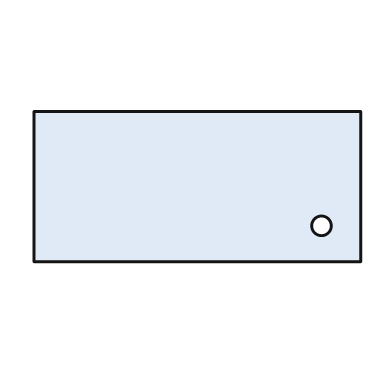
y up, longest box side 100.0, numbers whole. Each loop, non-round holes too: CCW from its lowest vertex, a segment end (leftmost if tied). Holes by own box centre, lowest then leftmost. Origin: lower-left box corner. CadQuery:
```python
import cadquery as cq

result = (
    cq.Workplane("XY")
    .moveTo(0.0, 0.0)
    .lineTo(100.0, 0.0)
    .lineTo(100.0, 46.0)
    .lineTo(0.0, 46.0)
    .close()
    .moveTo(88.0, 11.0)
    .circle(3.0)
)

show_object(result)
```